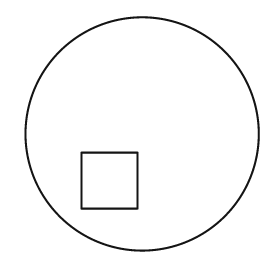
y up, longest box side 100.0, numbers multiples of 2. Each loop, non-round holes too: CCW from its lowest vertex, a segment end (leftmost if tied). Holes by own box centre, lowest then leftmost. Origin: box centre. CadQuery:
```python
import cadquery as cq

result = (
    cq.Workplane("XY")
    .moveTo(0.0, 0.0)
    .circle(50.0)
    .moveTo(-26.0, -32.0)
    .lineTo(-2.0, -32.0)
    .lineTo(-2.0, -8.0)
    .lineTo(-26.0, -8.0)
    .close()
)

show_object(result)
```